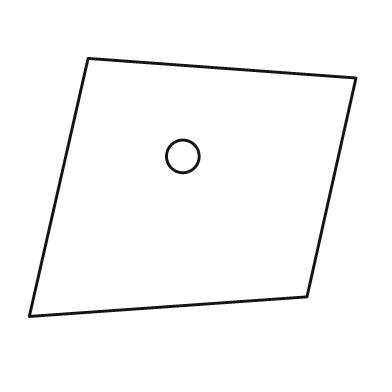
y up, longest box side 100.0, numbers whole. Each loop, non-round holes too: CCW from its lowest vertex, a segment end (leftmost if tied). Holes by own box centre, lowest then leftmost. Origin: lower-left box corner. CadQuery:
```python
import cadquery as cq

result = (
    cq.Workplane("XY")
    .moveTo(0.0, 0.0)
    .lineTo(85.0, 6.0)
    .lineTo(100.0, 73.0)
    .lineTo(18.0, 79.0)
    .close()
    .moveTo(47.0, 49.0)
    .circle(5.0)
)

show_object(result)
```